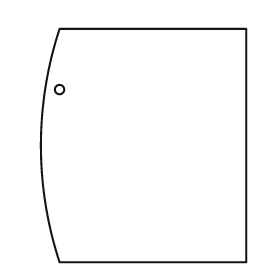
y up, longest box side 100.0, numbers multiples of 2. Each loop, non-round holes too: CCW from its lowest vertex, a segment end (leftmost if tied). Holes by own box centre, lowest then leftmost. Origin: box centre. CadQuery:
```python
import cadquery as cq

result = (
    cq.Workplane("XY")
    .moveTo(-36.0, -50.0)
    .lineTo(44.0, -50.0)
    .lineTo(44.0, 50.0)
    .lineTo(-36.0, 50.0)
    .threePointArc((-44.0, 0.0), (-36.0, -50.0))
    .close()
    .moveTo(-36.0, 24.0)
    .circle(2.0)
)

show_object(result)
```